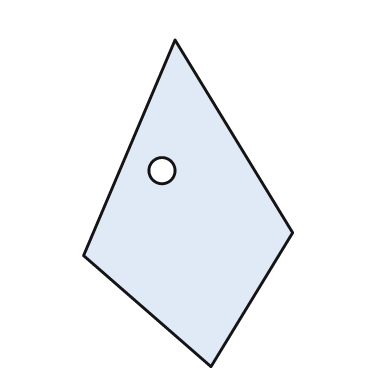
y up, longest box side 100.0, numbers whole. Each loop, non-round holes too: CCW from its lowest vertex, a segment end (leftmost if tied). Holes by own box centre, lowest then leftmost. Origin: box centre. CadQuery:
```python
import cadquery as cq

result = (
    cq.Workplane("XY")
    .moveTo(7.0, -50.0)
    .lineTo(32.0, -9.0)
    .lineTo(-4.0, 50.0)
    .lineTo(-32.0, -16.0)
    .close()
    .moveTo(-8.0, 10.0)
    .circle(4.0)
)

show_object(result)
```